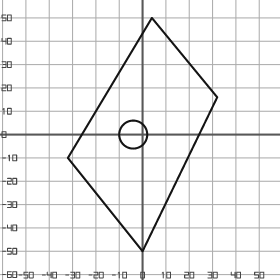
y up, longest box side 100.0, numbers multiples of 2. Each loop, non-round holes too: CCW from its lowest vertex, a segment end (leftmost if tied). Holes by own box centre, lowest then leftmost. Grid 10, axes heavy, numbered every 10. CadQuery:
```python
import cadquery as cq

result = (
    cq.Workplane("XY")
    .moveTo(0.0, -50.0)
    .lineTo(32.0, 16.0)
    .lineTo(4.0, 50.0)
    .lineTo(-32.0, -10.0)
    .close()
    .moveTo(-4.0, 0.0)
    .circle(6.0)
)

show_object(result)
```